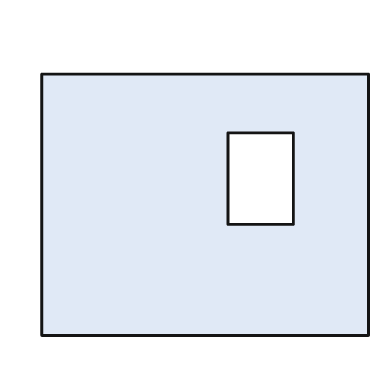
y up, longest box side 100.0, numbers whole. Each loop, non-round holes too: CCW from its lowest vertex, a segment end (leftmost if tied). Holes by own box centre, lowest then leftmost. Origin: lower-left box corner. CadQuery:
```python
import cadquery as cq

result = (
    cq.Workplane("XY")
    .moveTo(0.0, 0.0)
    .lineTo(100.0, 0.0)
    .lineTo(100.0, 80.0)
    .lineTo(0.0, 80.0)
    .close()
    .moveTo(57.0, 34.0)
    .lineTo(77.0, 34.0)
    .lineTo(77.0, 62.0)
    .lineTo(57.0, 62.0)
    .close()
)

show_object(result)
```